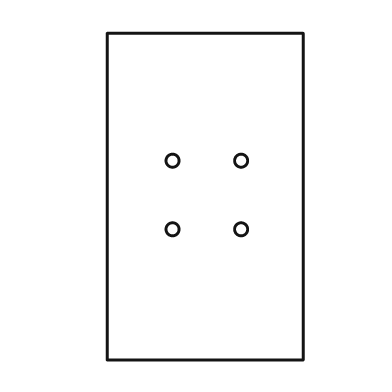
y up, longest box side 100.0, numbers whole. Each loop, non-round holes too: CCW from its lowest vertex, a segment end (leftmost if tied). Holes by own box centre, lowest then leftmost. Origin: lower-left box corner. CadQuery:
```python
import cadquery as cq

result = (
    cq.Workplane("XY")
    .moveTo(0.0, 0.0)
    .lineTo(60.0, 0.0)
    .lineTo(60.0, 100.0)
    .lineTo(0.0, 100.0)
    .close()
    .moveTo(20.0, 40.0)
    .circle(2.0)
    .moveTo(41.0, 40.0)
    .circle(2.0)
    .moveTo(20.0, 61.0)
    .circle(2.0)
    .moveTo(41.0, 61.0)
    .circle(2.0)
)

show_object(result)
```